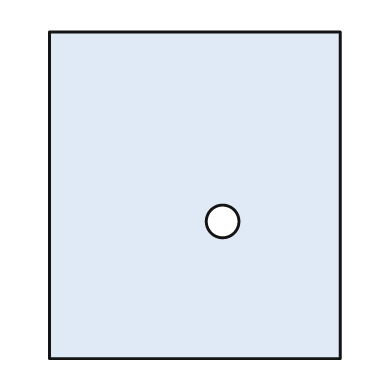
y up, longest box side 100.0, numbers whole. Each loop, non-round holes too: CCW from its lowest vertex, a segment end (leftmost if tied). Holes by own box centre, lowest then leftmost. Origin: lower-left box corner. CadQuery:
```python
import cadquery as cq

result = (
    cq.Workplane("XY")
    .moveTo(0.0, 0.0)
    .lineTo(89.0, 0.0)
    .lineTo(89.0, 100.0)
    .lineTo(0.0, 100.0)
    .close()
    .moveTo(53.0, 42.0)
    .circle(5.0)
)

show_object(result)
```